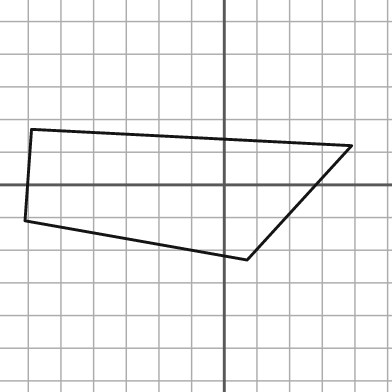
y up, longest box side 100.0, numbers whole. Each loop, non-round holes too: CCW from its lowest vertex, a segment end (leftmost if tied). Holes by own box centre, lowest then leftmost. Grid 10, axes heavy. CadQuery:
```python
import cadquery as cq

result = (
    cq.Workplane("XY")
    .moveTo(7.0, -23.0)
    .lineTo(39.0, 12.0)
    .lineTo(-59.0, 17.0)
    .lineTo(-61.0, -11.0)
    .close()
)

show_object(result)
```